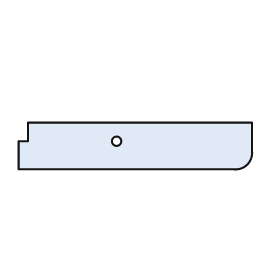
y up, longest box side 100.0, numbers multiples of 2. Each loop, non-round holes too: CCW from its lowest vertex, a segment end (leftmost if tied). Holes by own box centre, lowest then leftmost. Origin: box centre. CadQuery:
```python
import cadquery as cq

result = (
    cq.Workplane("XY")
    .moveTo(-50.0, -10.0)
    .lineTo(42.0, -10.0)
    .threePointArc((48.0, -8.0), (50.0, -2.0))
    .lineTo(50.0, 10.0)
    .lineTo(-46.0, 10.0)
    .lineTo(-46.0, 2.0)
    .lineTo(-50.0, 2.0)
    .close()
    .moveTo(-8.0, 2.0)
    .circle(2.0)
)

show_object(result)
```